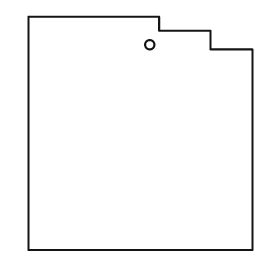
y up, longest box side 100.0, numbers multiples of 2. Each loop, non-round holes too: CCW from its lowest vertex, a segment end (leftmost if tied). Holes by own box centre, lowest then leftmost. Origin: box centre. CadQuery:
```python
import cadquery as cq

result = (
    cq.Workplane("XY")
    .moveTo(-48.0, -50.0)
    .lineTo(48.0, -50.0)
    .lineTo(48.0, 36.0)
    .lineTo(30.0, 36.0)
    .lineTo(30.0, 44.0)
    .lineTo(8.0, 44.0)
    .lineTo(8.0, 50.0)
    .lineTo(-48.0, 50.0)
    .close()
    .moveTo(4.0, 38.0)
    .circle(2.0)
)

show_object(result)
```